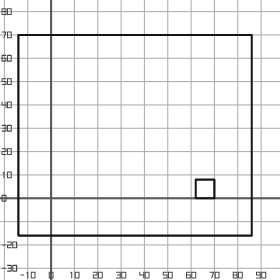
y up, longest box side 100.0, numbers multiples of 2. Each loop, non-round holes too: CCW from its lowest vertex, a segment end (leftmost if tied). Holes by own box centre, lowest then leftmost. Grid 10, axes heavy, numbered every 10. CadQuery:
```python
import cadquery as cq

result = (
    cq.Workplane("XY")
    .moveTo(-14.0, -16.0)
    .lineTo(86.0, -16.0)
    .lineTo(86.0, 70.0)
    .lineTo(-14.0, 70.0)
    .close()
    .moveTo(62.0, 0.0)
    .lineTo(70.0, 0.0)
    .lineTo(70.0, 8.0)
    .lineTo(62.0, 8.0)
    .close()
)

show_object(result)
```